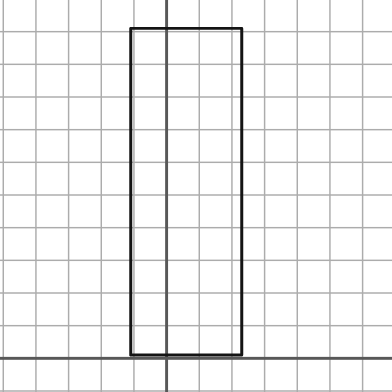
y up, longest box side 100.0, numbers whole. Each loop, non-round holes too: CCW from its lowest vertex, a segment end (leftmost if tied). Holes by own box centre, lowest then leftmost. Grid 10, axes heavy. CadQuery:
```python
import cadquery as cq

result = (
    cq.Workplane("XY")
    .moveTo(-11.0, 1.0)
    .lineTo(23.0, 1.0)
    .lineTo(23.0, 101.0)
    .lineTo(-11.0, 101.0)
    .close()
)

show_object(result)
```